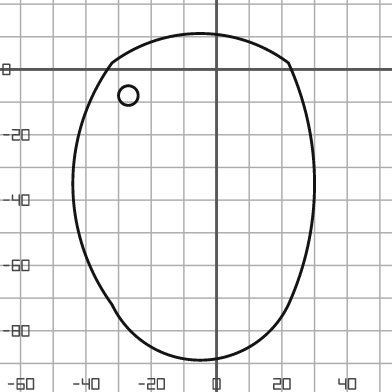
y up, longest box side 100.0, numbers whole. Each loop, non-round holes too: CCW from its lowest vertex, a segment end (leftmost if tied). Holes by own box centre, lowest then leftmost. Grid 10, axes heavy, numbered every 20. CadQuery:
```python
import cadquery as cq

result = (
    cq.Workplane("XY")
    .moveTo(-32.0, -72.0)
    .threePointArc((-5.0, -89.0), (22.0, -72.0))
    .threePointArc((30.0, -35.0), (22.0, 2.0))
    .threePointArc((-5.0, 11.0), (-32.0, 2.0))
    .threePointArc((-44.0, -35.0), (-32.0, -72.0))
    .close()
    .moveTo(-27.0, -8.0)
    .circle(3.0)
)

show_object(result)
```